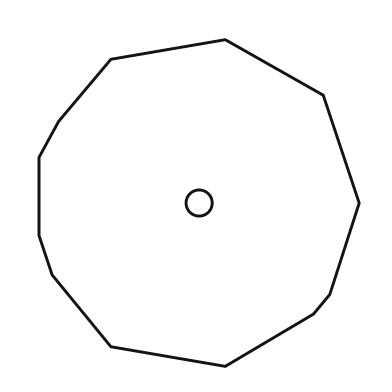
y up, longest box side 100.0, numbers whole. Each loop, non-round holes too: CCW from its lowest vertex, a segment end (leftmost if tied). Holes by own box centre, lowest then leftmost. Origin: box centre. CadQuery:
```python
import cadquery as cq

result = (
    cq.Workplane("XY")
    .moveTo(8.0, -50.0)
    .lineTo(35.0, -34.0)
    .lineTo(40.0, -28.0)
    .lineTo(49.0, 0.0)
    .lineTo(38.0, 33.0)
    .lineTo(8.0, 50.0)
    .lineTo(-27.0, 44.0)
    .lineTo(-43.0, 25.0)
    .lineTo(-49.0, 14.0)
    .lineTo(-49.0, -10.0)
    .lineTo(-45.0, -22.0)
    .lineTo(-27.0, -44.0)
    .close()
    .moveTo(0.0, 0.0)
    .circle(4.0)
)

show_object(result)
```